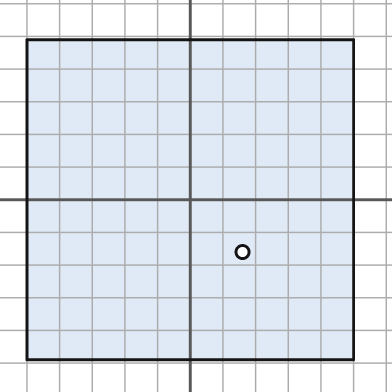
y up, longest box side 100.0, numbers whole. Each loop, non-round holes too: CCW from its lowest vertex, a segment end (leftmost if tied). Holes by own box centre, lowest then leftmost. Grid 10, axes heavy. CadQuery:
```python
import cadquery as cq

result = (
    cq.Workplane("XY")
    .moveTo(-50.0, -49.0)
    .lineTo(50.0, -49.0)
    .lineTo(50.0, 49.0)
    .lineTo(-50.0, 49.0)
    .close()
    .moveTo(16.0, -16.0)
    .circle(2.0)
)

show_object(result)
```